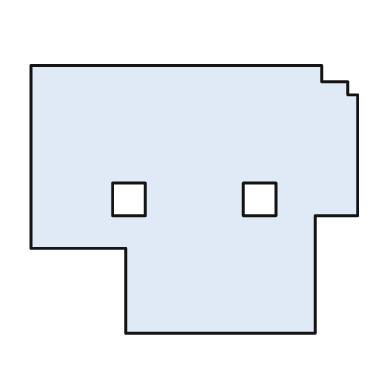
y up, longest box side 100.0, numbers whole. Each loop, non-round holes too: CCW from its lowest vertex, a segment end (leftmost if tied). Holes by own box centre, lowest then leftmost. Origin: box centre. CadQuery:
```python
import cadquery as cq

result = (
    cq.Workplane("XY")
    .moveTo(-21.0, -41.0)
    .lineTo(37.0, -41.0)
    .lineTo(37.0, -5.0)
    .lineTo(50.0, -5.0)
    .lineTo(50.0, 32.0)
    .lineTo(47.0, 32.0)
    .lineTo(47.0, 36.0)
    .lineTo(39.0, 36.0)
    .lineTo(39.0, 41.0)
    .lineTo(-50.0, 41.0)
    .lineTo(-50.0, -15.0)
    .lineTo(-21.0, -15.0)
    .close()
    .moveTo(-25.0, -5.0)
    .lineTo(-15.0, -5.0)
    .lineTo(-15.0, 5.0)
    .lineTo(-25.0, 5.0)
    .close()
    .moveTo(15.0, -5.0)
    .lineTo(25.0, -5.0)
    .lineTo(25.0, 5.0)
    .lineTo(15.0, 5.0)
    .close()
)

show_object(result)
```